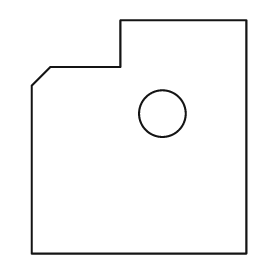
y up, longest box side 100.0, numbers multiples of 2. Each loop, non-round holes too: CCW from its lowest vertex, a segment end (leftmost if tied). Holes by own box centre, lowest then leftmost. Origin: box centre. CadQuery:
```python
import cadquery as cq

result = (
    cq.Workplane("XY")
    .moveTo(-46.0, -50.0)
    .lineTo(46.0, -50.0)
    .lineTo(46.0, 50.0)
    .lineTo(-8.0, 50.0)
    .lineTo(-8.0, 30.0)
    .lineTo(-38.0, 30.0)
    .lineTo(-46.0, 22.0)
    .close()
    .moveTo(10.0, 10.0)
    .circle(10.0)
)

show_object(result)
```